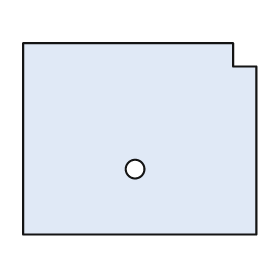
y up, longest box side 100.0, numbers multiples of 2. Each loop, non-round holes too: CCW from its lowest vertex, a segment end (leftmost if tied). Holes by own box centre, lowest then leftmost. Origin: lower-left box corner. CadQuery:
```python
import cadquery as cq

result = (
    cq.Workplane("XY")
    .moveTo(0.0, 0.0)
    .lineTo(100.0, 0.0)
    .lineTo(100.0, 72.0)
    .lineTo(90.0, 72.0)
    .lineTo(90.0, 82.0)
    .lineTo(0.0, 82.0)
    .close()
    .moveTo(48.0, 28.0)
    .circle(4.0)
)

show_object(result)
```